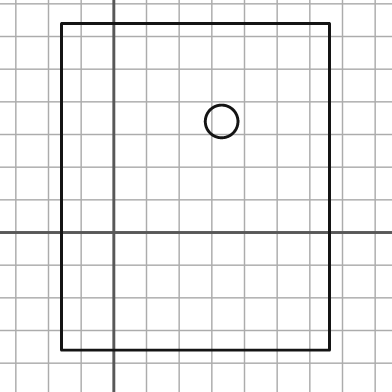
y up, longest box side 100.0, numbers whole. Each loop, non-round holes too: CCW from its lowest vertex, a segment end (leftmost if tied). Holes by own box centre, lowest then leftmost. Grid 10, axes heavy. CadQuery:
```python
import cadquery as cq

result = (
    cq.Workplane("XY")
    .moveTo(-16.0, -36.0)
    .lineTo(66.0, -36.0)
    .lineTo(66.0, 64.0)
    .lineTo(-16.0, 64.0)
    .close()
    .moveTo(33.0, 34.0)
    .circle(5.0)
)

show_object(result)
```